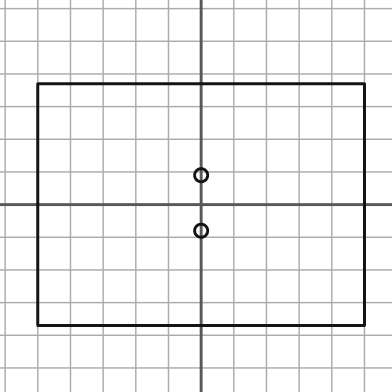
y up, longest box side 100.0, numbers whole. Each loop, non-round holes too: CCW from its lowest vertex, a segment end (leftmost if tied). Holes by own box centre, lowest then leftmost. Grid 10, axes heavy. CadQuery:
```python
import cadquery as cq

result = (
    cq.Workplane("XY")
    .moveTo(-50.0, -37.0)
    .lineTo(50.0, -37.0)
    .lineTo(50.0, 37.0)
    .lineTo(-50.0, 37.0)
    .close()
    .moveTo(0.0, -8.0)
    .circle(2.0)
    .moveTo(0.0, 9.0)
    .circle(2.0)
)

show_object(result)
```